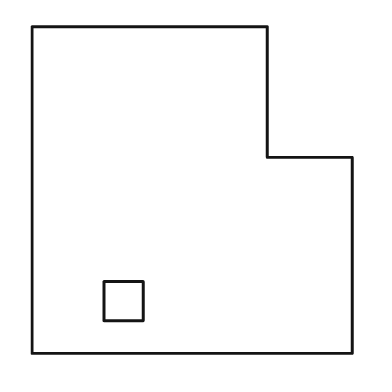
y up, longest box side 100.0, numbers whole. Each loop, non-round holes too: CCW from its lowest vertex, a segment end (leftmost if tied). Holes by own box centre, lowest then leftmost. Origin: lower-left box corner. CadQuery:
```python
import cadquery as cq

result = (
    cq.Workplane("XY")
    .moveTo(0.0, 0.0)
    .lineTo(98.0, 0.0)
    .lineTo(98.0, 60.0)
    .lineTo(72.0, 60.0)
    .lineTo(72.0, 100.0)
    .lineTo(0.0, 100.0)
    .close()
    .moveTo(22.0, 10.0)
    .lineTo(34.0, 10.0)
    .lineTo(34.0, 22.0)
    .lineTo(22.0, 22.0)
    .close()
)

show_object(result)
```